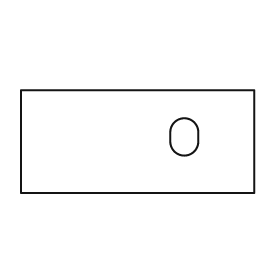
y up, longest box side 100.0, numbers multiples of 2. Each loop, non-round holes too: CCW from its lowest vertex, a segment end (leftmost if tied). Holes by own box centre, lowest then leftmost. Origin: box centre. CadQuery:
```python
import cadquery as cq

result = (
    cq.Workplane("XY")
    .moveTo(-50.0, -22.0)
    .lineTo(50.0, -22.0)
    .lineTo(50.0, 22.0)
    .lineTo(-50.0, 22.0)
    .close()
    .moveTo(14.0, 0.0)
    .threePointArc((20.0, -6.0), (26.0, 0.0))
    .lineTo(26.0, 4.0)
    .threePointArc((20.0, 10.0), (14.0, 4.0))
    .close()
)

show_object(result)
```